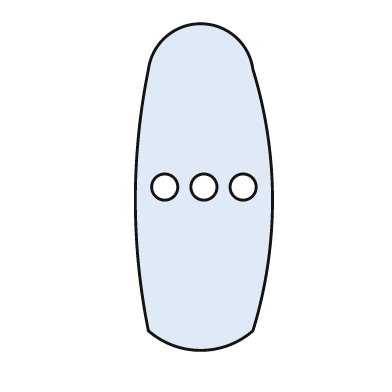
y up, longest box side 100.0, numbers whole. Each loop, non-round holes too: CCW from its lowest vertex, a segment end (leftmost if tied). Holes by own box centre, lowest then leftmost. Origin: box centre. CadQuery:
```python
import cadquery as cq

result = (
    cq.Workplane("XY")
    .moveTo(-17.0, -44.0)
    .threePointArc((-1.0, -50.0), (15.0, -44.0))
    .threePointArc((21.0, -4.0), (15.0, 36.0))
    .threePointArc((-1.0, 50.0), (-17.0, 36.0))
    .threePointArc((-21.0, -4.0), (-17.0, -44.0))
    .close()
    .moveTo(-12.0, 0.0)
    .circle(4.0)
    .moveTo(0.0, 0.0)
    .circle(4.0)
    .moveTo(12.0, 0.0)
    .circle(4.0)
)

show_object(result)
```